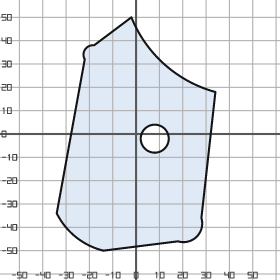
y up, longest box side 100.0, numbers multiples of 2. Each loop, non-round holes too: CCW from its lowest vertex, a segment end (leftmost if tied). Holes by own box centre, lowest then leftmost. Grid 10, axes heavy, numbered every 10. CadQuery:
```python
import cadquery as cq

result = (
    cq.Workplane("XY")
    .moveTo(-14.0, -50.0)
    .lineTo(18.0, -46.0)
    .threePointArc((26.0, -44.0), (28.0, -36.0))
    .lineTo(34.0, 18.0)
    .threePointArc((12.0, 30.0), (-2.0, 50.0))
    .lineTo(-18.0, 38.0)
    .threePointArc((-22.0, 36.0), (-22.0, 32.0))
    .lineTo(-34.0, -34.0)
    .threePointArc((-26.0, -44.0), (-14.0, -50.0))
    .close()
    .moveTo(8.0, -2.0)
    .circle(6.0)
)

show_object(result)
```